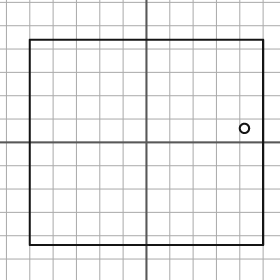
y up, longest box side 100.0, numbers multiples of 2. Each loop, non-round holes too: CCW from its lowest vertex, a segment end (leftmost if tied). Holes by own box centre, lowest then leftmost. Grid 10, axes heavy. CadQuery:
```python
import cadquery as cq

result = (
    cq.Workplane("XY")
    .moveTo(-50.0, -44.0)
    .lineTo(50.0, -44.0)
    .lineTo(50.0, 44.0)
    .lineTo(-50.0, 44.0)
    .close()
    .moveTo(42.0, 6.0)
    .circle(2.0)
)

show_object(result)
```